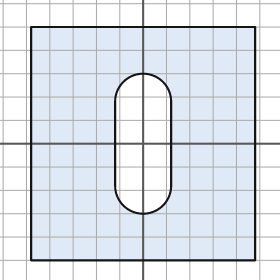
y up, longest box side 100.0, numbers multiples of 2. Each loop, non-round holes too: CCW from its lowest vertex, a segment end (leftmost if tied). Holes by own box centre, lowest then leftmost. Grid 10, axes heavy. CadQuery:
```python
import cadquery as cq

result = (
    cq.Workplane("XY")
    .moveTo(-48.0, -50.0)
    .lineTo(48.0, -50.0)
    .lineTo(48.0, 50.0)
    .lineTo(-48.0, 50.0)
    .close()
    .moveTo(-12.0, -18.0)
    .threePointArc((0.0, -30.0), (12.0, -18.0))
    .lineTo(12.0, 18.0)
    .threePointArc((0.0, 30.0), (-12.0, 18.0))
    .close()
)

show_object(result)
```